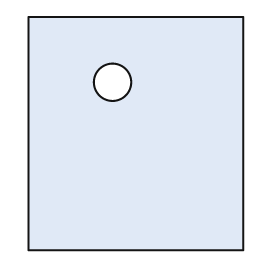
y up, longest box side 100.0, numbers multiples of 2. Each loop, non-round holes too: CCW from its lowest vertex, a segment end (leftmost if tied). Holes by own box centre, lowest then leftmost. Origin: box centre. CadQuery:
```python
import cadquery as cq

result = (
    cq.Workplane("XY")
    .moveTo(-46.0, -50.0)
    .lineTo(46.0, -50.0)
    .lineTo(46.0, 50.0)
    .lineTo(-46.0, 50.0)
    .close()
    .moveTo(-10.0, 22.0)
    .circle(8.0)
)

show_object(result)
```